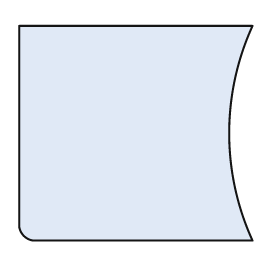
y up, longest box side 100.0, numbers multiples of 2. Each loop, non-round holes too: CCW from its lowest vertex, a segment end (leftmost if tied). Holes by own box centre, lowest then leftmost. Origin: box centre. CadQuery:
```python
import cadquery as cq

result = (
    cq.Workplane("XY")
    .moveTo(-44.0, -46.0)
    .lineTo(50.0, -46.0)
    .threePointArc((40.0, 0.0), (50.0, 46.0))
    .lineTo(-50.0, 46.0)
    .lineTo(-50.0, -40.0)
    .threePointArc((-48.0, -44.0), (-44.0, -46.0))
    .close()
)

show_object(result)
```